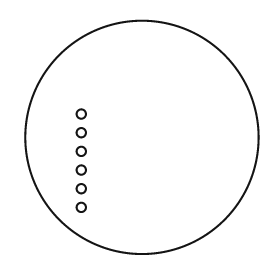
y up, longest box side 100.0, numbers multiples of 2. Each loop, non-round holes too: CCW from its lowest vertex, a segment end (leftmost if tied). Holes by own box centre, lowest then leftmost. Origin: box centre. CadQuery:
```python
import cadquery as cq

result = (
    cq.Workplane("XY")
    .moveTo(0.0, 0.0)
    .circle(50.0)
    .moveTo(-26.0, -30.0)
    .circle(2.0)
    .moveTo(-26.0, -22.0)
    .circle(2.0)
    .moveTo(-26.0, -14.0)
    .circle(2.0)
    .moveTo(-26.0, -6.0)
    .circle(2.0)
    .moveTo(-26.0, 2.0)
    .circle(2.0)
    .moveTo(-26.0, 10.0)
    .circle(2.0)
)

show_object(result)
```